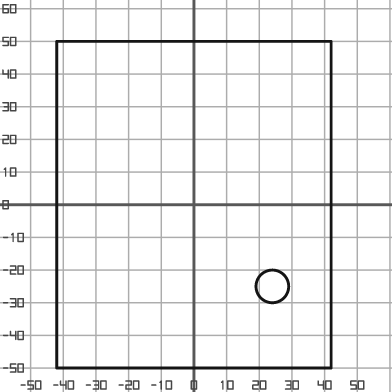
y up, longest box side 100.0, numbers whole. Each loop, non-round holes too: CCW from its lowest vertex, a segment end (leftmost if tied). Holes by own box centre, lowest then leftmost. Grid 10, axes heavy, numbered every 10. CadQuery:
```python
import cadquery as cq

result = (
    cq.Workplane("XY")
    .moveTo(-42.0, -50.0)
    .lineTo(42.0, -50.0)
    .lineTo(42.0, 50.0)
    .lineTo(-42.0, 50.0)
    .close()
    .moveTo(24.0, -25.0)
    .circle(5.0)
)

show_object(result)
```